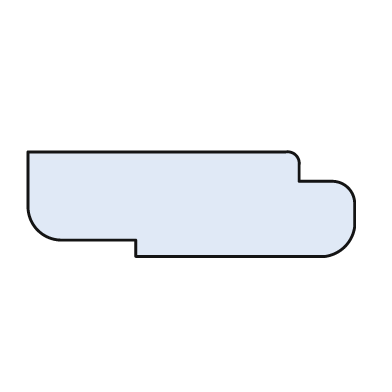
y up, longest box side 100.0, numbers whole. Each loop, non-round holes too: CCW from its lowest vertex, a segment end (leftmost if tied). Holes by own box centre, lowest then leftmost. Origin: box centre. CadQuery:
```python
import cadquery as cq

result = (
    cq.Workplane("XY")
    .moveTo(-17.0, -16.0)
    .lineTo(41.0, -16.0)
    .threePointArc((47.0, -13.0), (50.0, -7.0))
    .lineTo(50.0, 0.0)
    .threePointArc((48.0, 5.0), (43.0, 7.0))
    .lineTo(33.0, 7.0)
    .lineTo(33.0, 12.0)
    .threePointArc((32.0, 15.0), (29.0, 16.0))
    .lineTo(-50.0, 16.0)
    .lineTo(-50.0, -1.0)
    .threePointArc((-47.0, -8.0), (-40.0, -11.0))
    .lineTo(-17.0, -11.0)
    .close()
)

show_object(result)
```